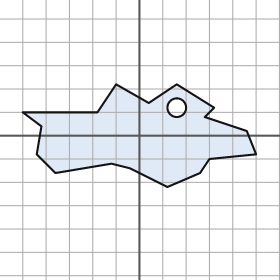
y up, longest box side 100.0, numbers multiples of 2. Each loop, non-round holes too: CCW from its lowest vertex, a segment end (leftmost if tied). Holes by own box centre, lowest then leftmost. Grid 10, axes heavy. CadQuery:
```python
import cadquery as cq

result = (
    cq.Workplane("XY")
    .moveTo(12.0, -22.0)
    .lineTo(26.0, -16.0)
    .lineTo(30.0, -10.0)
    .lineTo(50.0, -8.0)
    .lineTo(46.0, 2.0)
    .lineTo(28.0, 8.0)
    .lineTo(32.0, 12.0)
    .lineTo(16.0, 22.0)
    .lineTo(4.0, 14.0)
    .lineTo(-10.0, 22.0)
    .lineTo(-18.0, 10.0)
    .lineTo(-50.0, 10.0)
    .lineTo(-42.0, 4.0)
    .lineTo(-44.0, -8.0)
    .lineTo(-36.0, -16.0)
    .lineTo(-12.0, -12.0)
    .lineTo(-4.0, -14.0)
    .close()
    .moveTo(16.0, 12.0)
    .circle(4.0)
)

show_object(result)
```